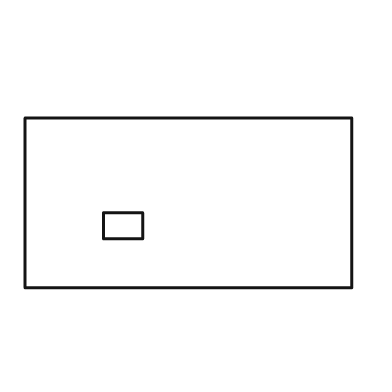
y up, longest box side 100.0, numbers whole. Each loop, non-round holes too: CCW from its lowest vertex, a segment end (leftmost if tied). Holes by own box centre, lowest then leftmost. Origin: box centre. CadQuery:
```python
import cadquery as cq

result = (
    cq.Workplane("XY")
    .moveTo(-50.0, -26.0)
    .lineTo(50.0, -26.0)
    .lineTo(50.0, 26.0)
    .lineTo(-50.0, 26.0)
    .close()
    .moveTo(-26.0, -11.0)
    .lineTo(-14.0, -11.0)
    .lineTo(-14.0, -3.0)
    .lineTo(-26.0, -3.0)
    .close()
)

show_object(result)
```